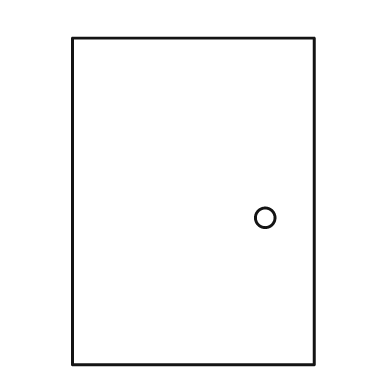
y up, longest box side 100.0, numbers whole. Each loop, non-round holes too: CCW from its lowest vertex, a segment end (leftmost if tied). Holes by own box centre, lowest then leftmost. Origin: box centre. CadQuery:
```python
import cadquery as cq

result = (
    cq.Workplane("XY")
    .moveTo(-37.0, -50.0)
    .lineTo(37.0, -50.0)
    .lineTo(37.0, 50.0)
    .lineTo(-37.0, 50.0)
    .close()
    .moveTo(22.0, -5.0)
    .circle(3.0)
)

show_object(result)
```